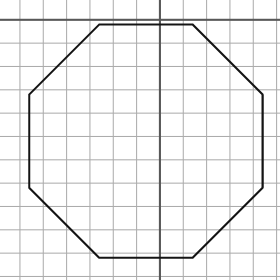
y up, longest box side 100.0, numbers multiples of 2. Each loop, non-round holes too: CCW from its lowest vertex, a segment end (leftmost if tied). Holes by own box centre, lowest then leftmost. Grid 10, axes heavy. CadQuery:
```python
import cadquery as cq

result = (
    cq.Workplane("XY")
    .moveTo(-26.0, -102.0)
    .lineTo(14.0, -102.0)
    .lineTo(44.0, -72.0)
    .lineTo(44.0, -32.0)
    .lineTo(14.0, -2.0)
    .lineTo(-26.0, -2.0)
    .lineTo(-56.0, -32.0)
    .lineTo(-56.0, -72.0)
    .close()
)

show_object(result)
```